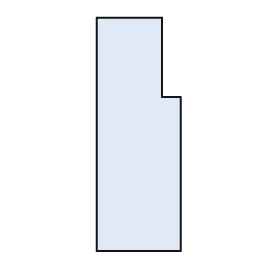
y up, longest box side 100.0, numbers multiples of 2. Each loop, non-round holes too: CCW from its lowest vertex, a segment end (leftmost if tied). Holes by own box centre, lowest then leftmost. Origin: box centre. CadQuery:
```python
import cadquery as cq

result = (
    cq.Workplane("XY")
    .moveTo(-18.0, -50.0)
    .lineTo(18.0, -50.0)
    .lineTo(18.0, 16.0)
    .lineTo(10.0, 16.0)
    .lineTo(10.0, 50.0)
    .lineTo(-18.0, 50.0)
    .close()
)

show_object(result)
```